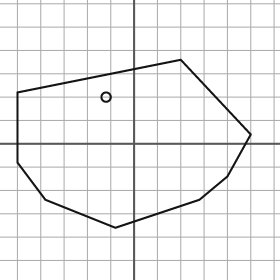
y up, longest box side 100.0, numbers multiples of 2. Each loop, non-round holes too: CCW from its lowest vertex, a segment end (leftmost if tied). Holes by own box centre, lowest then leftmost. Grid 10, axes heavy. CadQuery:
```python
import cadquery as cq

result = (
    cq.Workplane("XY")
    .moveTo(-8.0, -36.0)
    .lineTo(28.0, -24.0)
    .lineTo(40.0, -14.0)
    .lineTo(50.0, 4.0)
    .lineTo(20.0, 36.0)
    .lineTo(-50.0, 22.0)
    .lineTo(-50.0, -8.0)
    .lineTo(-38.0, -24.0)
    .close()
    .moveTo(-12.0, 20.0)
    .circle(2.0)
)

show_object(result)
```